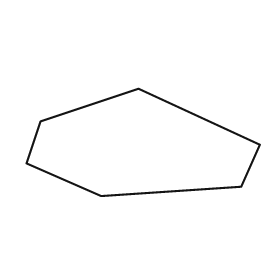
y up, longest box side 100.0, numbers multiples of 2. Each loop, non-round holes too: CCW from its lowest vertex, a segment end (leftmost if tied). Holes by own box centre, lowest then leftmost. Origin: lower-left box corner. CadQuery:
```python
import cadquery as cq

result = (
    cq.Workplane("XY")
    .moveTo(32.0, 0.0)
    .lineTo(92.0, 4.0)
    .lineTo(100.0, 22.0)
    .lineTo(48.0, 46.0)
    .lineTo(6.0, 32.0)
    .lineTo(0.0, 14.0)
    .close()
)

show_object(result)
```